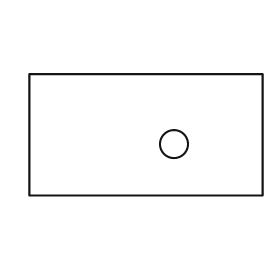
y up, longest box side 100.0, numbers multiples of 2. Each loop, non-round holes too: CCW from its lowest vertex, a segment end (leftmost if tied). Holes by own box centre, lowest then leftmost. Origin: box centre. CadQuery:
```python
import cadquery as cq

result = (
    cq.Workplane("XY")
    .moveTo(-50.0, -26.0)
    .lineTo(50.0, -26.0)
    .lineTo(50.0, 26.0)
    .lineTo(-50.0, 26.0)
    .close()
    .moveTo(12.0, -4.0)
    .circle(6.0)
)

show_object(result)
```